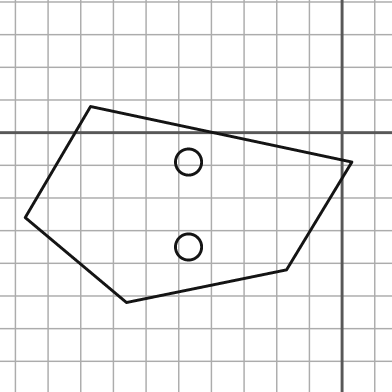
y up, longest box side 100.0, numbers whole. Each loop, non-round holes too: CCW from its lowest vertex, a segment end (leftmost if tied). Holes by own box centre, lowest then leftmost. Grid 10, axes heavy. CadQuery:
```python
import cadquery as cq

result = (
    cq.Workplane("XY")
    .moveTo(-66.0, -52.0)
    .lineTo(-17.0, -42.0)
    .lineTo(3.0, -9.0)
    .lineTo(-77.0, 8.0)
    .lineTo(-97.0, -26.0)
    .close()
    .moveTo(-47.0, -35.0)
    .circle(4.0)
    .moveTo(-47.0, -9.0)
    .circle(4.0)
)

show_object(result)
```